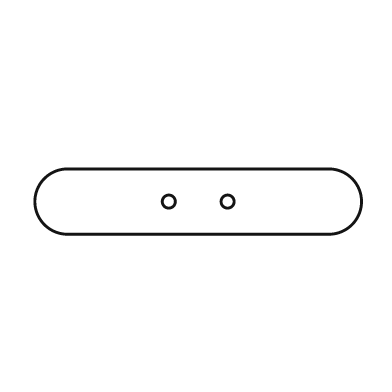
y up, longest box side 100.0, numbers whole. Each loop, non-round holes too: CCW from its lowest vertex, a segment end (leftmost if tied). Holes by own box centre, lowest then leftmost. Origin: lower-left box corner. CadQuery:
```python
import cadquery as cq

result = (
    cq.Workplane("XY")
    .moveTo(10.0, 0.0)
    .lineTo(90.0, 0.0)
    .threePointArc((100.0, 10.0), (90.0, 20.0))
    .lineTo(10.0, 20.0)
    .threePointArc((0.0, 10.0), (10.0, 0.0))
    .close()
    .moveTo(41.0, 10.0)
    .circle(2.0)
    .moveTo(59.0, 10.0)
    .circle(2.0)
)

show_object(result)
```